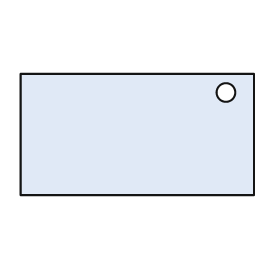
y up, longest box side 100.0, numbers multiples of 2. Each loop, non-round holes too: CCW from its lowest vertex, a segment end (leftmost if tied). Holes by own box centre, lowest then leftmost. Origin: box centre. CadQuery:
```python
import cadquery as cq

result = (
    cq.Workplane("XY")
    .moveTo(-50.0, -26.0)
    .lineTo(50.0, -26.0)
    .lineTo(50.0, 26.0)
    .lineTo(-50.0, 26.0)
    .close()
    .moveTo(38.0, 18.0)
    .circle(4.0)
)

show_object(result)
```